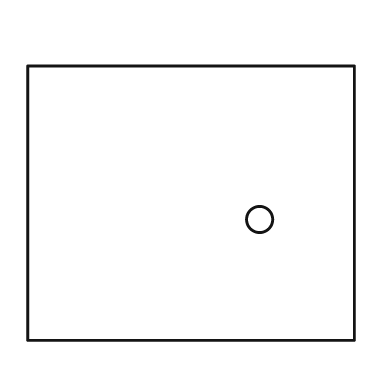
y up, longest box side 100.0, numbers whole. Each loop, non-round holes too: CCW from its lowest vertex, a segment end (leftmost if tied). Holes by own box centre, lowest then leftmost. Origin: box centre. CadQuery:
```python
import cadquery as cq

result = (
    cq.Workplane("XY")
    .moveTo(-50.0, -42.0)
    .lineTo(50.0, -42.0)
    .lineTo(50.0, 42.0)
    .lineTo(-50.0, 42.0)
    .close()
    .moveTo(21.0, -5.0)
    .circle(4.0)
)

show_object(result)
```